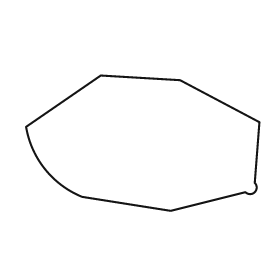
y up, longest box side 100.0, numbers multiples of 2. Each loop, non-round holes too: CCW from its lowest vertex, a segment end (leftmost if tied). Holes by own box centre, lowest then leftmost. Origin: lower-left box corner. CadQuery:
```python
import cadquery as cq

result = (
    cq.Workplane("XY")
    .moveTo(62.0, 0.0)
    .lineTo(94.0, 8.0)
    .threePointArc((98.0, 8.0), (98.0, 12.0))
    .lineTo(100.0, 38.0)
    .lineTo(66.0, 56.0)
    .lineTo(32.0, 58.0)
    .lineTo(0.0, 36.0)
    .threePointArc((8.0, 18.0), (24.0, 6.0))
    .close()
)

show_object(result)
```